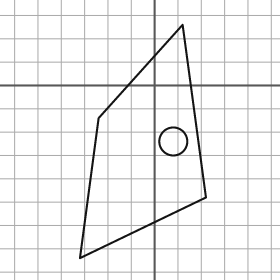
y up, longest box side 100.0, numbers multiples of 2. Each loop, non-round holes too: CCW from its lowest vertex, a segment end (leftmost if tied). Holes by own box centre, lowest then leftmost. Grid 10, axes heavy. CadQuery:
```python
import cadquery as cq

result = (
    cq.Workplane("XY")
    .moveTo(-32.0, -74.0)
    .lineTo(22.0, -48.0)
    .lineTo(12.0, 26.0)
    .lineTo(-24.0, -14.0)
    .close()
    .moveTo(8.0, -24.0)
    .circle(6.0)
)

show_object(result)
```